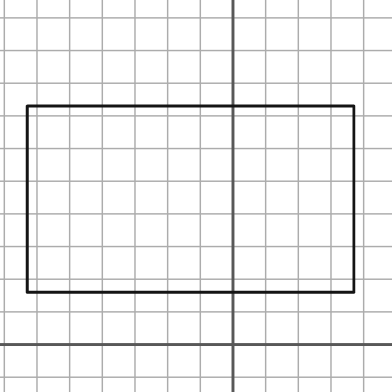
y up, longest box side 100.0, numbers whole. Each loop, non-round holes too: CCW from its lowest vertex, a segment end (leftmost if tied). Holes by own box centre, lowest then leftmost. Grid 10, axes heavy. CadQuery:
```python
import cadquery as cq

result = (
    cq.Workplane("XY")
    .moveTo(-63.0, 16.0)
    .lineTo(37.0, 16.0)
    .lineTo(37.0, 73.0)
    .lineTo(-63.0, 73.0)
    .close()
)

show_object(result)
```